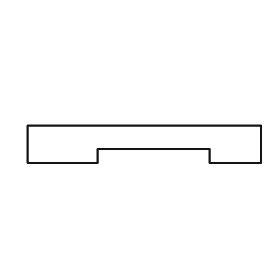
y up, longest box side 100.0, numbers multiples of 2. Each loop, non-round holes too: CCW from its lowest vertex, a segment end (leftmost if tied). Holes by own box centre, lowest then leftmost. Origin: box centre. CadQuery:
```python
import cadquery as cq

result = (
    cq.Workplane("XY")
    .moveTo(-50.0, -8.0)
    .lineTo(-20.0, -8.0)
    .lineTo(-20.0, -2.0)
    .lineTo(28.0, -2.0)
    .lineTo(28.0, -8.0)
    .lineTo(50.0, -8.0)
    .lineTo(50.0, 8.0)
    .lineTo(-50.0, 8.0)
    .close()
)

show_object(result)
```